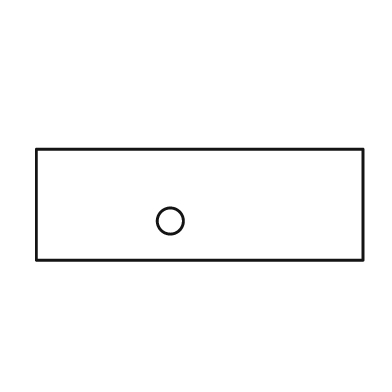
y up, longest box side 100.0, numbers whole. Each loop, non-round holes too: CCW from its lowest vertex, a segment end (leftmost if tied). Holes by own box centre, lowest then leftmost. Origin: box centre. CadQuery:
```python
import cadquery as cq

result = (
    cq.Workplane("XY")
    .moveTo(-50.0, -17.0)
    .lineTo(50.0, -17.0)
    .lineTo(50.0, 17.0)
    .lineTo(-50.0, 17.0)
    .close()
    .moveTo(-9.0, -5.0)
    .circle(4.0)
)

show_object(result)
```